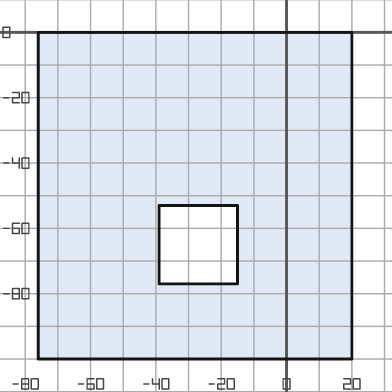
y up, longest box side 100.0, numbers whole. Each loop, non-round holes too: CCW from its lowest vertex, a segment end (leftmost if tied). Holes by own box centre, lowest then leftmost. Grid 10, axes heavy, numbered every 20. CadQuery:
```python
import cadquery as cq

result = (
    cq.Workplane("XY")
    .moveTo(-76.0, -100.0)
    .lineTo(20.0, -100.0)
    .lineTo(20.0, 0.0)
    .lineTo(-76.0, 0.0)
    .close()
    .moveTo(-39.0, -77.0)
    .lineTo(-15.0, -77.0)
    .lineTo(-15.0, -53.0)
    .lineTo(-39.0, -53.0)
    .close()
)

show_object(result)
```